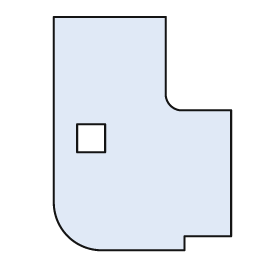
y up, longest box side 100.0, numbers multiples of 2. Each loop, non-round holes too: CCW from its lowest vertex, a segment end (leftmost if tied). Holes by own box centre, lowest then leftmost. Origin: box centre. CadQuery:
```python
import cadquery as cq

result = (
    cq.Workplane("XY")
    .moveTo(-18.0, -50.0)
    .lineTo(18.0, -50.0)
    .lineTo(18.0, -44.0)
    .lineTo(38.0, -44.0)
    .lineTo(38.0, 10.0)
    .lineTo(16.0, 10.0)
    .threePointArc((12.0, 12.0), (10.0, 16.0))
    .lineTo(10.0, 50.0)
    .lineTo(-38.0, 50.0)
    .lineTo(-38.0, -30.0)
    .threePointArc((-32.0, -44.0), (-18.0, -50.0))
    .close()
    .moveTo(-28.0, -8.0)
    .lineTo(-16.0, -8.0)
    .lineTo(-16.0, 4.0)
    .lineTo(-28.0, 4.0)
    .close()
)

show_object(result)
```